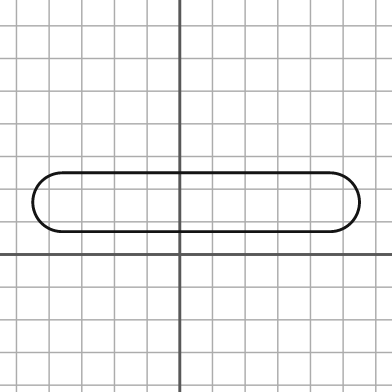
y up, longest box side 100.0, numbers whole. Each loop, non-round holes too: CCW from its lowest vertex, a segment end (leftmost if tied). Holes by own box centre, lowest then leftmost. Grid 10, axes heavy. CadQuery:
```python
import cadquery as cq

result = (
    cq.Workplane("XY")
    .moveTo(-36.0, 7.0)
    .lineTo(46.0, 7.0)
    .threePointArc((55.0, 16.0), (46.0, 25.0))
    .lineTo(-36.0, 25.0)
    .threePointArc((-45.0, 16.0), (-36.0, 7.0))
    .close()
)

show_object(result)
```